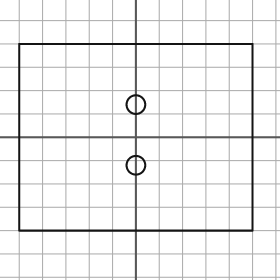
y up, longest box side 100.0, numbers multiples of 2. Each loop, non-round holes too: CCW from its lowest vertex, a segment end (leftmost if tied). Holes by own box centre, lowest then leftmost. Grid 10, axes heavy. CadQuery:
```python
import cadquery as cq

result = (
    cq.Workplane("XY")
    .moveTo(-50.0, -40.0)
    .lineTo(50.0, -40.0)
    .lineTo(50.0, 40.0)
    .lineTo(-50.0, 40.0)
    .close()
    .moveTo(0.0, -12.0)
    .circle(4.0)
    .moveTo(0.0, 14.0)
    .circle(4.0)
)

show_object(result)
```